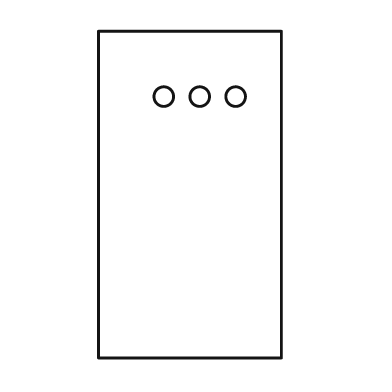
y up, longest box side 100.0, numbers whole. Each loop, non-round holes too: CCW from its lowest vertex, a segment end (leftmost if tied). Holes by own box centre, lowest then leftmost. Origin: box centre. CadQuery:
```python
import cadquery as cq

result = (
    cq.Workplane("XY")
    .moveTo(-28.0, -50.0)
    .lineTo(28.0, -50.0)
    .lineTo(28.0, 50.0)
    .lineTo(-28.0, 50.0)
    .close()
    .moveTo(-8.0, 30.0)
    .circle(3.0)
    .moveTo(3.0, 30.0)
    .circle(3.0)
    .moveTo(14.0, 30.0)
    .circle(3.0)
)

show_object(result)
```